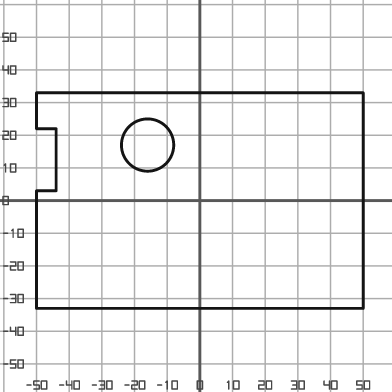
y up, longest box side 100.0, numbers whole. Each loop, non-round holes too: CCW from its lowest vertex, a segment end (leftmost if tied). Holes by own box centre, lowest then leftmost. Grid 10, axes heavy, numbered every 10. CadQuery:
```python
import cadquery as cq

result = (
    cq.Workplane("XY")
    .moveTo(-50.0, -33.0)
    .lineTo(50.0, -33.0)
    .lineTo(50.0, 33.0)
    .lineTo(-50.0, 33.0)
    .lineTo(-50.0, 22.0)
    .lineTo(-44.0, 22.0)
    .lineTo(-44.0, 3.0)
    .lineTo(-50.0, 3.0)
    .close()
    .moveTo(-16.0, 17.0)
    .circle(8.0)
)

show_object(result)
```